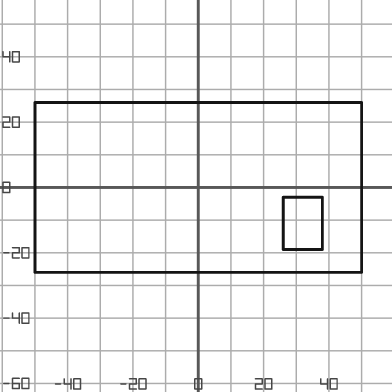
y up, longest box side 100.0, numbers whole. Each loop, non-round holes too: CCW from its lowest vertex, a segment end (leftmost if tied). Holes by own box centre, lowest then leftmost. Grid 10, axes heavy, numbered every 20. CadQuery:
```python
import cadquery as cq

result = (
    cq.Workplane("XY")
    .moveTo(-50.0, -26.0)
    .lineTo(50.0, -26.0)
    .lineTo(50.0, 26.0)
    .lineTo(-50.0, 26.0)
    .close()
    .moveTo(26.0, -19.0)
    .lineTo(38.0, -19.0)
    .lineTo(38.0, -3.0)
    .lineTo(26.0, -3.0)
    .close()
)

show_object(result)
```